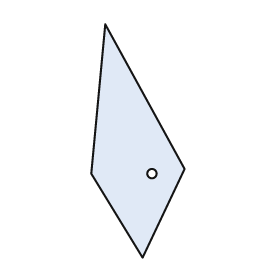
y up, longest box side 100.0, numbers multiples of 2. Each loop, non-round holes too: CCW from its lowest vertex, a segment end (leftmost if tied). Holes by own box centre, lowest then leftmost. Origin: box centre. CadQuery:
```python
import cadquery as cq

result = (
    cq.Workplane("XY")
    .moveTo(2.0, -50.0)
    .lineTo(20.0, -12.0)
    .lineTo(-14.0, 50.0)
    .lineTo(-20.0, -14.0)
    .close()
    .moveTo(6.0, -14.0)
    .circle(2.0)
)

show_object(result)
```